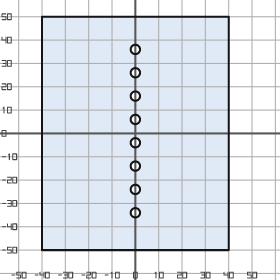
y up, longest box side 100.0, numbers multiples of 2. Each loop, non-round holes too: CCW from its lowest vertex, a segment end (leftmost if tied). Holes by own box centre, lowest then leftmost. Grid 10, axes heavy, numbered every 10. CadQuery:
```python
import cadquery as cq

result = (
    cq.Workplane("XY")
    .moveTo(-40.0, -50.0)
    .lineTo(40.0, -50.0)
    .lineTo(40.0, 50.0)
    .lineTo(-40.0, 50.0)
    .close()
    .moveTo(0.0, -34.0)
    .circle(2.0)
    .moveTo(0.0, -24.0)
    .circle(2.0)
    .moveTo(0.0, -14.0)
    .circle(2.0)
    .moveTo(0.0, -4.0)
    .circle(2.0)
    .moveTo(0.0, 6.0)
    .circle(2.0)
    .moveTo(0.0, 16.0)
    .circle(2.0)
    .moveTo(0.0, 26.0)
    .circle(2.0)
    .moveTo(0.0, 36.0)
    .circle(2.0)
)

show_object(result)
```